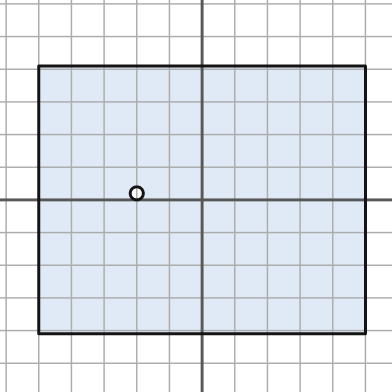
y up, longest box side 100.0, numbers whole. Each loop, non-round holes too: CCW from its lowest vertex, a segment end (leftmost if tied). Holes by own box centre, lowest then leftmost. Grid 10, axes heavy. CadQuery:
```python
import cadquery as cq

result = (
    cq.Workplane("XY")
    .moveTo(-50.0, -41.0)
    .lineTo(50.0, -41.0)
    .lineTo(50.0, 41.0)
    .lineTo(-50.0, 41.0)
    .close()
    .moveTo(-20.0, 2.0)
    .circle(2.0)
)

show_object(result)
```